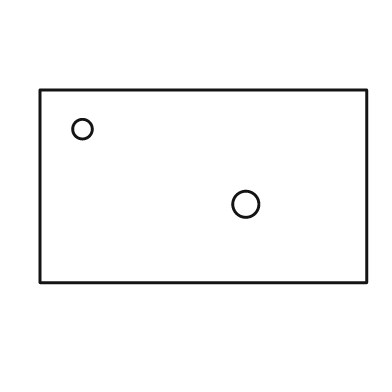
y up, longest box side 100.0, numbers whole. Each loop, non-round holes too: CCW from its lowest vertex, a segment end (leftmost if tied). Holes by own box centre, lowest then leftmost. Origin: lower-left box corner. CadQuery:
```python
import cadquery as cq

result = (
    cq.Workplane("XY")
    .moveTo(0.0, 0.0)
    .lineTo(100.0, 0.0)
    .lineTo(100.0, 59.0)
    .lineTo(0.0, 59.0)
    .close()
    .moveTo(63.0, 24.0)
    .circle(4.0)
    .moveTo(13.0, 47.0)
    .circle(3.0)
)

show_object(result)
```